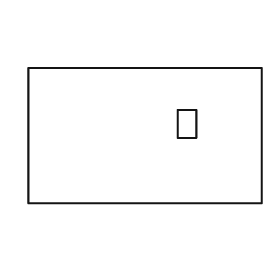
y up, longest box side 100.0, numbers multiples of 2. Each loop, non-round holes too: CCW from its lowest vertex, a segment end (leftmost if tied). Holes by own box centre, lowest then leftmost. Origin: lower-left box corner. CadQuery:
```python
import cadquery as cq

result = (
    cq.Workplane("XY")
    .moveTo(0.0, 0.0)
    .lineTo(100.0, 0.0)
    .lineTo(100.0, 58.0)
    .lineTo(0.0, 58.0)
    .close()
    .moveTo(64.0, 28.0)
    .lineTo(72.0, 28.0)
    .lineTo(72.0, 40.0)
    .lineTo(64.0, 40.0)
    .close()
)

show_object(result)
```